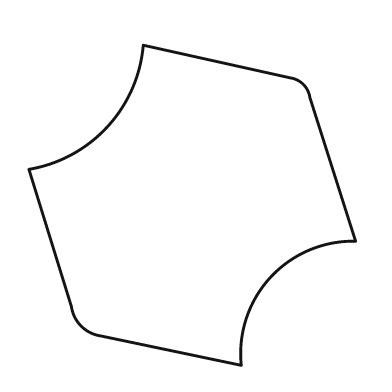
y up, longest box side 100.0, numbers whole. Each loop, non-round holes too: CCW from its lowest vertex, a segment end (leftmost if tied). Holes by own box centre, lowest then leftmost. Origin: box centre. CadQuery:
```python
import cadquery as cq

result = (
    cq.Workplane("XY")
    .moveTo(15.0, -49.0)
    .threePointArc((24.0, -22.0), (50.0, -11.0))
    .lineTo(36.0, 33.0)
    .threePointArc((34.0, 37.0), (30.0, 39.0))
    .lineTo(-15.0, 49.0)
    .threePointArc((-26.0, 24.0), (-50.0, 11.0))
    .lineTo(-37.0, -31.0)
    .threePointArc((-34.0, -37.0), (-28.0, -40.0))
    .close()
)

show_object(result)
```